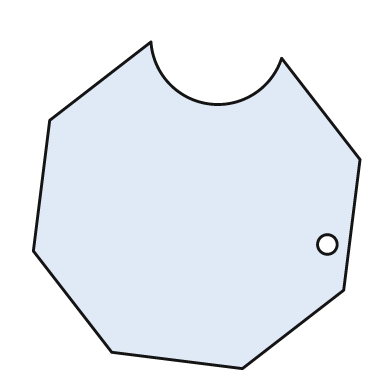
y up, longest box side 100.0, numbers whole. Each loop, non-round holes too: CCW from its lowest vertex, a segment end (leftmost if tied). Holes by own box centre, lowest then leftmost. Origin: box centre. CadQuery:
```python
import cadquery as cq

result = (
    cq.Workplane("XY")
    .moveTo(14.0, -50.0)
    .lineTo(45.0, -26.0)
    .lineTo(50.0, 14.0)
    .lineTo(26.0, 45.0)
    .threePointArc((4.0, 31.0), (-14.0, 50.0))
    .lineTo(-45.0, 26.0)
    .lineTo(-50.0, -14.0)
    .lineTo(-26.0, -45.0)
    .close()
    .moveTo(40.0, -12.0)
    .circle(3.0)
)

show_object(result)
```